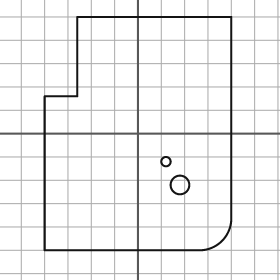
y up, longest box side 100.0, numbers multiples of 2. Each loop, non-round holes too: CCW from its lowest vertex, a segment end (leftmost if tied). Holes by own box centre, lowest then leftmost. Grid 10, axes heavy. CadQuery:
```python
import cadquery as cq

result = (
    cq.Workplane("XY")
    .moveTo(-40.0, -50.0)
    .lineTo(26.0, -50.0)
    .threePointArc((36.0, -46.0), (40.0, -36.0))
    .lineTo(40.0, 50.0)
    .lineTo(-26.0, 50.0)
    .lineTo(-26.0, 16.0)
    .lineTo(-40.0, 16.0)
    .close()
    .moveTo(18.0, -22.0)
    .circle(4.0)
    .moveTo(12.0, -12.0)
    .circle(2.0)
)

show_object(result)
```